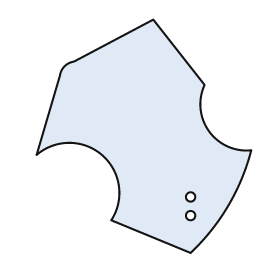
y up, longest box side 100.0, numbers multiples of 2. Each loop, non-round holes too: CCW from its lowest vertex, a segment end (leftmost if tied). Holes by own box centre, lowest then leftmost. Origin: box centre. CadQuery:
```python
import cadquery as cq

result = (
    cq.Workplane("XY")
    .moveTo(20.0, -50.0)
    .threePointArc((36.0, -30.0), (46.0, -6.0))
    .threePointArc((28.0, 2.0), (26.0, 22.0))
    .lineTo(4.0, 50.0)
    .lineTo(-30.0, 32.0)
    .threePointArc((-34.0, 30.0), (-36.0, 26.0))
    .lineTo(-46.0, -8.0)
    .threePointArc((-18.0, -8.0), (-14.0, -36.0))
    .close()
    .moveTo(20.0, -34.0)
    .circle(2.0)
    .moveTo(20.0, -26.0)
    .circle(2.0)
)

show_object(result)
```